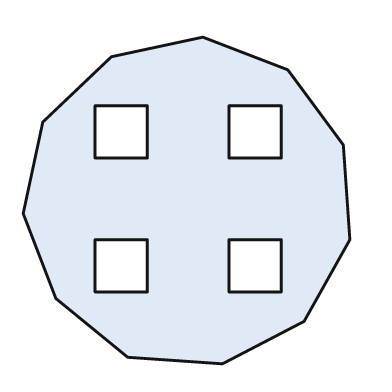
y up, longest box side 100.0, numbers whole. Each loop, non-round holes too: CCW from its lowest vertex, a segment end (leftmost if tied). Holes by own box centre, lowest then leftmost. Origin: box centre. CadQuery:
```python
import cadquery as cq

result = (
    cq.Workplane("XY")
    .moveTo(11.0, -50.0)
    .lineTo(36.0, -37.0)
    .lineTo(50.0, -12.0)
    .lineTo(48.0, 17.0)
    .lineTo(31.0, 40.0)
    .lineTo(5.0, 50.0)
    .lineTo(-23.0, 44.0)
    .lineTo(-44.0, 24.0)
    .lineTo(-50.0, -4.0)
    .lineTo(-40.0, -30.0)
    .lineTo(-18.0, -48.0)
    .close()
    .moveTo(-28.0, -28.0)
    .lineTo(-12.0, -28.0)
    .lineTo(-12.0, -12.0)
    .lineTo(-28.0, -12.0)
    .close()
    .moveTo(13.0, -28.0)
    .lineTo(29.0, -28.0)
    .lineTo(29.0, -12.0)
    .lineTo(13.0, -12.0)
    .close()
    .moveTo(-28.0, 13.0)
    .lineTo(-12.0, 13.0)
    .lineTo(-12.0, 29.0)
    .lineTo(-28.0, 29.0)
    .close()
    .moveTo(13.0, 13.0)
    .lineTo(29.0, 13.0)
    .lineTo(29.0, 29.0)
    .lineTo(13.0, 29.0)
    .close()
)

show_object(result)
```